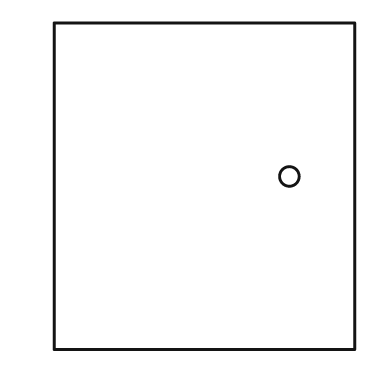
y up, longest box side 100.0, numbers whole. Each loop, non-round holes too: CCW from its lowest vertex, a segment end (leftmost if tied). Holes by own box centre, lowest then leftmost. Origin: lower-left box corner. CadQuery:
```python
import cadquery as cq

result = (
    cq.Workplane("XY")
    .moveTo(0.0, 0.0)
    .lineTo(92.0, 0.0)
    .lineTo(92.0, 100.0)
    .lineTo(0.0, 100.0)
    .close()
    .moveTo(72.0, 53.0)
    .circle(3.0)
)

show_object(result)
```